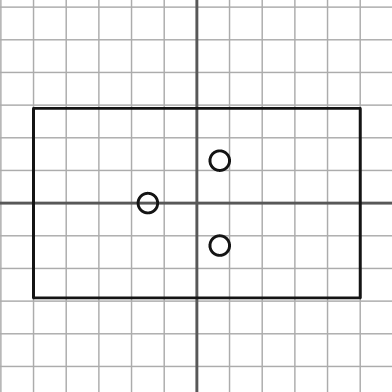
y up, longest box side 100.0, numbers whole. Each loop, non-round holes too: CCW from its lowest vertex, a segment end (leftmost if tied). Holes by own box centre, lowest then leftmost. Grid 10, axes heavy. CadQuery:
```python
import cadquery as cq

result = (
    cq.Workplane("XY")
    .moveTo(-50.0, -29.0)
    .lineTo(50.0, -29.0)
    .lineTo(50.0, 29.0)
    .lineTo(-50.0, 29.0)
    .close()
    .moveTo(7.0, -13.0)
    .circle(3.0)
    .moveTo(-15.0, 0.0)
    .circle(3.0)
    .moveTo(7.0, 13.0)
    .circle(3.0)
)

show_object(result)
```